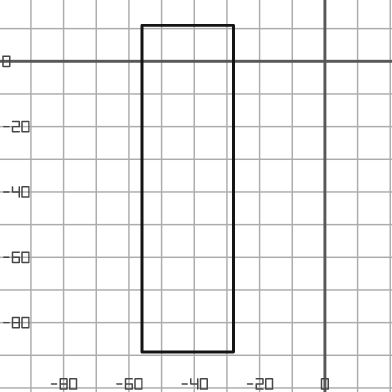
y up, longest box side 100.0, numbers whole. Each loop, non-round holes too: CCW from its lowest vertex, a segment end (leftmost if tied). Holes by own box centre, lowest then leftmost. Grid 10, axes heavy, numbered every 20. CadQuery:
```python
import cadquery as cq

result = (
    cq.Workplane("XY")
    .moveTo(-56.0, -89.0)
    .lineTo(-28.0, -89.0)
    .lineTo(-28.0, 11.0)
    .lineTo(-56.0, 11.0)
    .close()
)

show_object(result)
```